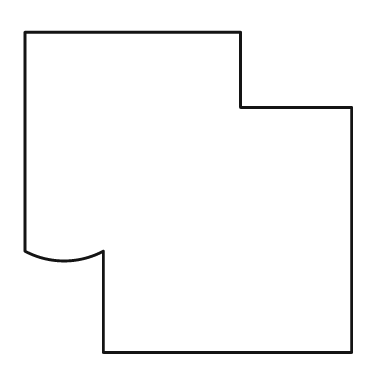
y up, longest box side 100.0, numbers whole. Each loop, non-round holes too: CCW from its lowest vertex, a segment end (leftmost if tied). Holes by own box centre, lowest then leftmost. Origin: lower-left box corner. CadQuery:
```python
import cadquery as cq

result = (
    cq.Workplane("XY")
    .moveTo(24.0, 0.0)
    .lineTo(100.0, 0.0)
    .lineTo(100.0, 75.0)
    .lineTo(66.0, 75.0)
    .lineTo(66.0, 98.0)
    .lineTo(0.0, 98.0)
    .lineTo(0.0, 31.0)
    .threePointArc((12.0, 28.0), (24.0, 31.0))
    .close()
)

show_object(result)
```